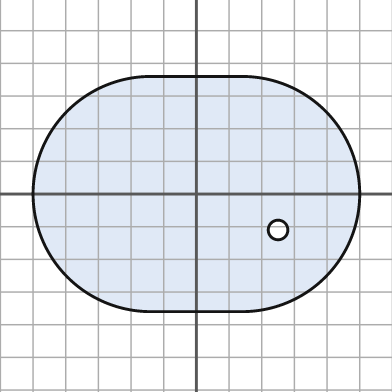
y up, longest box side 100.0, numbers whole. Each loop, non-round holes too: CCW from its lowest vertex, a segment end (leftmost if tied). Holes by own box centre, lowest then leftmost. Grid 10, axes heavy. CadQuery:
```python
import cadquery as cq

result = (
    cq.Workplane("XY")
    .moveTo(-14.0, -36.0)
    .lineTo(14.0, -36.0)
    .threePointArc((50.0, 0.0), (14.0, 36.0))
    .lineTo(-14.0, 36.0)
    .threePointArc((-50.0, 0.0), (-14.0, -36.0))
    .close()
    .moveTo(25.0, -11.0)
    .circle(3.0)
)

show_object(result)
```